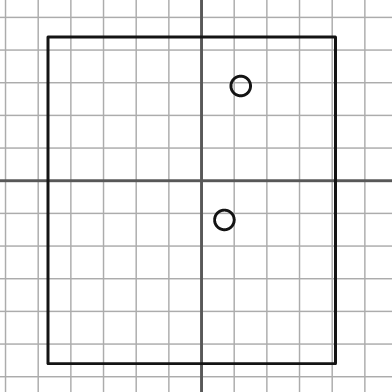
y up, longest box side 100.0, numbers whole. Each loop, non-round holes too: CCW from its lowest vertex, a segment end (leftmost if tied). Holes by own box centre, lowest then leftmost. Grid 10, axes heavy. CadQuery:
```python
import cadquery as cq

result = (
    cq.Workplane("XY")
    .moveTo(-47.0, -56.0)
    .lineTo(41.0, -56.0)
    .lineTo(41.0, 44.0)
    .lineTo(-47.0, 44.0)
    .close()
    .moveTo(7.0, -12.0)
    .circle(3.0)
    .moveTo(12.0, 29.0)
    .circle(3.0)
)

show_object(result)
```